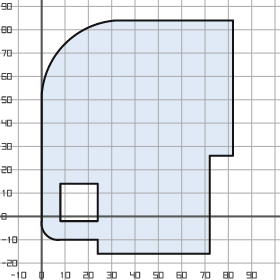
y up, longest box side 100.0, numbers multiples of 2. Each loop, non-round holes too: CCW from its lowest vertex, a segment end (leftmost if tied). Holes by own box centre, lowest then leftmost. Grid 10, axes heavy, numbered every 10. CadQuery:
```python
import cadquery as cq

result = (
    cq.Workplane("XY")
    .moveTo(24.0, -16.0)
    .lineTo(72.0, -16.0)
    .lineTo(72.0, 26.0)
    .lineTo(82.0, 26.0)
    .lineTo(82.0, 84.0)
    .lineTo(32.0, 84.0)
    .threePointArc((10.0, 74.0), (0.0, 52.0))
    .lineTo(0.0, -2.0)
    .threePointArc((2.0, -8.0), (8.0, -10.0))
    .lineTo(24.0, -10.0)
    .close()
    .moveTo(8.0, -2.0)
    .lineTo(24.0, -2.0)
    .lineTo(24.0, 14.0)
    .lineTo(8.0, 14.0)
    .close()
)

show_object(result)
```